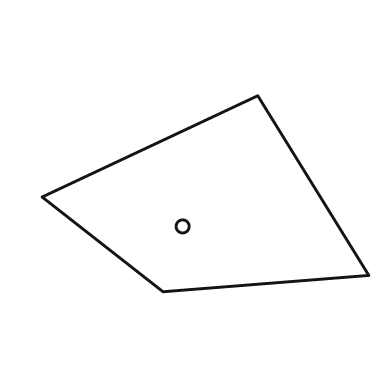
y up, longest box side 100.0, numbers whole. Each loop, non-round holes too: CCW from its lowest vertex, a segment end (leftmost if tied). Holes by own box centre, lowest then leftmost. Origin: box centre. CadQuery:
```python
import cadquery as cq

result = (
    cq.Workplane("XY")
    .moveTo(-13.0, -30.0)
    .lineTo(50.0, -25.0)
    .lineTo(16.0, 30.0)
    .lineTo(-50.0, -1.0)
    .close()
    .moveTo(-7.0, -10.0)
    .circle(2.0)
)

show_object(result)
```